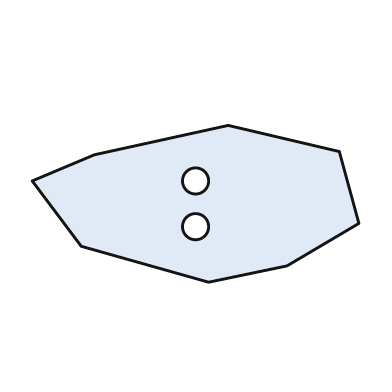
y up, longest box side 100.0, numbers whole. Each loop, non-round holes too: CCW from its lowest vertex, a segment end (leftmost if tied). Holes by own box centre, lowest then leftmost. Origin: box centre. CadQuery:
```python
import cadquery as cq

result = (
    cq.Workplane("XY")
    .moveTo(4.0, -24.0)
    .lineTo(28.0, -19.0)
    .lineTo(50.0, -6.0)
    .lineTo(44.0, 16.0)
    .lineTo(10.0, 24.0)
    .lineTo(-31.0, 15.0)
    .lineTo(-50.0, 7.0)
    .lineTo(-35.0, -13.0)
    .close()
    .moveTo(0.0, -7.0)
    .circle(4.0)
    .moveTo(0.0, 7.0)
    .circle(4.0)
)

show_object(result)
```